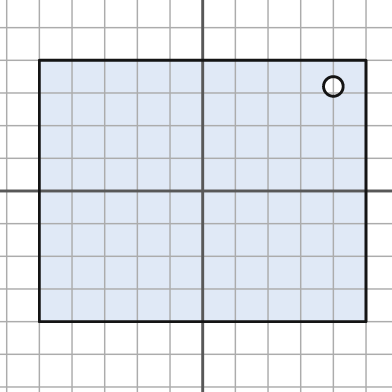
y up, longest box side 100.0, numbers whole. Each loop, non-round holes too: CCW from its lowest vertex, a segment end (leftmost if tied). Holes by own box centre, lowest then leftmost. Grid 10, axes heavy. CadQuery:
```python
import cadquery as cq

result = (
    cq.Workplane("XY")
    .moveTo(-50.0, -40.0)
    .lineTo(50.0, -40.0)
    .lineTo(50.0, 40.0)
    .lineTo(-50.0, 40.0)
    .close()
    .moveTo(40.0, 32.0)
    .circle(3.0)
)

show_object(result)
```